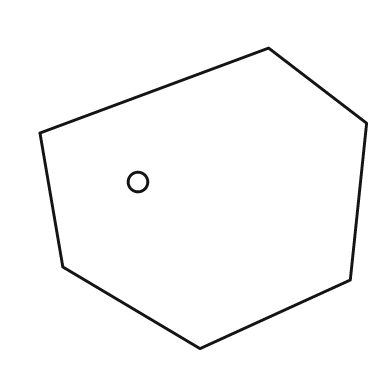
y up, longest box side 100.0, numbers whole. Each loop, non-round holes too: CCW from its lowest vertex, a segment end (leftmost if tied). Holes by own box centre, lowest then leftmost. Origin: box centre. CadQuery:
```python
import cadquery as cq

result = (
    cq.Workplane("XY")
    .moveTo(-1.0, -46.0)
    .lineTo(45.0, -25.0)
    .lineTo(50.0, 23.0)
    .lineTo(20.0, 46.0)
    .lineTo(-50.0, 20.0)
    .lineTo(-43.0, -21.0)
    .close()
    .moveTo(-20.0, 5.0)
    .circle(3.0)
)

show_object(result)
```